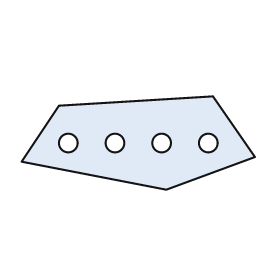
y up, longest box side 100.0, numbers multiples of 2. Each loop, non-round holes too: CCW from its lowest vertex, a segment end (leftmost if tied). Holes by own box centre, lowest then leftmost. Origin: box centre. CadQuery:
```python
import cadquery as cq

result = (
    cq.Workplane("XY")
    .moveTo(12.0, -20.0)
    .lineTo(50.0, -6.0)
    .lineTo(32.0, 20.0)
    .lineTo(-34.0, 16.0)
    .lineTo(-50.0, -8.0)
    .close()
    .moveTo(-30.0, 0.0)
    .circle(4.0)
    .moveTo(-10.0, 0.0)
    .circle(4.0)
    .moveTo(10.0, 0.0)
    .circle(4.0)
    .moveTo(30.0, 0.0)
    .circle(4.0)
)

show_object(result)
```